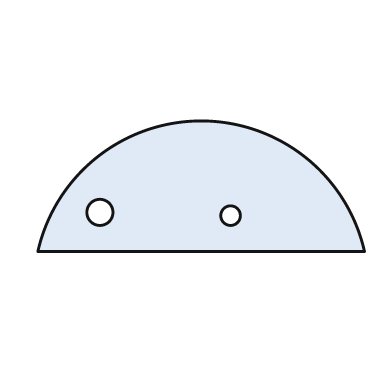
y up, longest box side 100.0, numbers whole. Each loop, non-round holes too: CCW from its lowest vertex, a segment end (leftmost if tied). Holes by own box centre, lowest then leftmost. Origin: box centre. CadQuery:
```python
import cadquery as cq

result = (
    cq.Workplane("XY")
    .moveTo(-50.0, -20.0)
    .lineTo(50.0, -20.0)
    .threePointArc((0.0, 20.0), (-50.0, -20.0))
    .close()
    .moveTo(9.0, -9.0)
    .circle(3.0)
    .moveTo(-31.0, -8.0)
    .circle(4.0)
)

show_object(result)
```